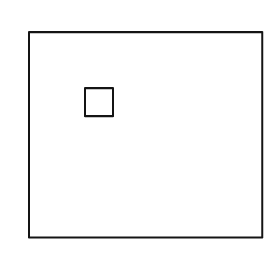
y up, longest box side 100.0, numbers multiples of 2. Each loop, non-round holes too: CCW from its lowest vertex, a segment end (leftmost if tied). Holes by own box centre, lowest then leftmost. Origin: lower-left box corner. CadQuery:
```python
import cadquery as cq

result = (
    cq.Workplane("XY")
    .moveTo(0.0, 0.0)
    .lineTo(100.0, 0.0)
    .lineTo(100.0, 88.0)
    .lineTo(0.0, 88.0)
    .close()
    .moveTo(24.0, 52.0)
    .lineTo(36.0, 52.0)
    .lineTo(36.0, 64.0)
    .lineTo(24.0, 64.0)
    .close()
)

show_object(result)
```